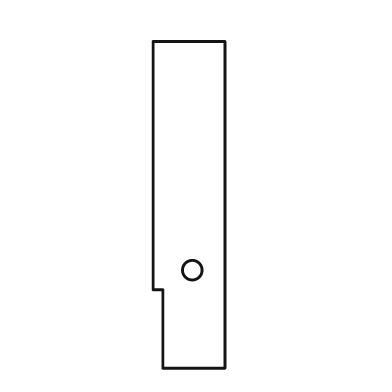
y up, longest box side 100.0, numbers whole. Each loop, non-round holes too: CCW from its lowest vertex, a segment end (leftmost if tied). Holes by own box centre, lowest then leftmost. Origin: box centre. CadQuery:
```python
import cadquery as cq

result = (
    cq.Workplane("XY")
    .moveTo(-8.0, -50.0)
    .lineTo(11.0, -50.0)
    .lineTo(11.0, 50.0)
    .lineTo(-11.0, 50.0)
    .lineTo(-11.0, -26.0)
    .lineTo(-8.0, -26.0)
    .close()
    .moveTo(1.0, -20.0)
    .circle(3.0)
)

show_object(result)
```